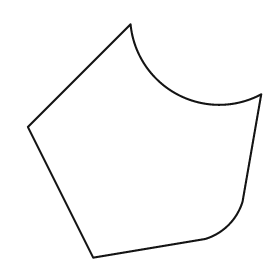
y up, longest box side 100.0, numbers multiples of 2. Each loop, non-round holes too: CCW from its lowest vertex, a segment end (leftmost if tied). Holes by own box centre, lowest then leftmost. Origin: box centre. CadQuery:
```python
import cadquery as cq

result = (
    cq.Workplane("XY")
    .moveTo(-22.0, -50.0)
    .lineTo(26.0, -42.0)
    .threePointArc((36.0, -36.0), (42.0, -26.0))
    .lineTo(50.0, 20.0)
    .threePointArc((14.0, 20.0), (-6.0, 50.0))
    .lineTo(-50.0, 6.0)
    .close()
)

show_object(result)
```